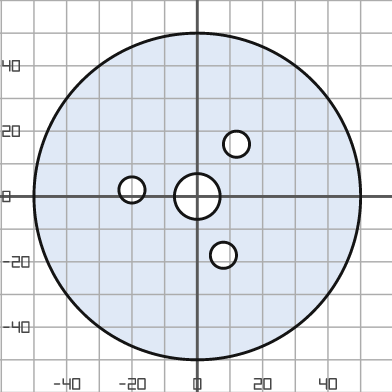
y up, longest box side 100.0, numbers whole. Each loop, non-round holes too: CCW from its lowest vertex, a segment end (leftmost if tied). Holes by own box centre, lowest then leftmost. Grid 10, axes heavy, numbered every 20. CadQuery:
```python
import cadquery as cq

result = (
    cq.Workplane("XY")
    .moveTo(0.0, 0.0)
    .circle(50.0)
    .moveTo(8.0, -18.0)
    .circle(4.0)
    .moveTo(0.0, 0.0)
    .circle(7.0)
    .moveTo(-20.0, 2.0)
    .circle(4.0)
    .moveTo(12.0, 16.0)
    .circle(4.0)
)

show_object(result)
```